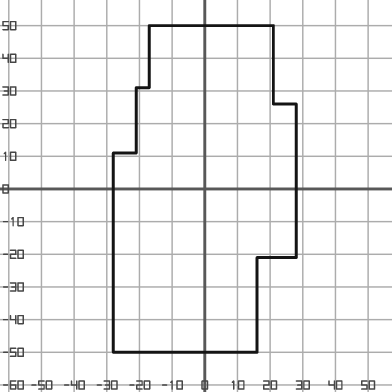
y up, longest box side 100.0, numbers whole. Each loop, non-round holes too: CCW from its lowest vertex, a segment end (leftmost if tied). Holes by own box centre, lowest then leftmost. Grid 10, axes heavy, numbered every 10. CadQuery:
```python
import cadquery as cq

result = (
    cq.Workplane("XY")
    .moveTo(-28.0, -50.0)
    .lineTo(16.0, -50.0)
    .lineTo(16.0, -21.0)
    .lineTo(28.0, -21.0)
    .lineTo(28.0, 26.0)
    .lineTo(21.0, 26.0)
    .lineTo(21.0, 50.0)
    .lineTo(-17.0, 50.0)
    .lineTo(-17.0, 31.0)
    .lineTo(-21.0, 31.0)
    .lineTo(-21.0, 11.0)
    .lineTo(-28.0, 11.0)
    .close()
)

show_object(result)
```